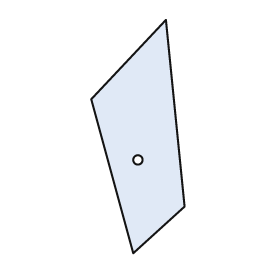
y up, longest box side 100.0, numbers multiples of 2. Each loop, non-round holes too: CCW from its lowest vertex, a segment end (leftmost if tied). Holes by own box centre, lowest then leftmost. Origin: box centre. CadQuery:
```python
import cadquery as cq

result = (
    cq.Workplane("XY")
    .moveTo(-2.0, -50.0)
    .lineTo(20.0, -30.0)
    .lineTo(12.0, 50.0)
    .lineTo(-20.0, 16.0)
    .close()
    .moveTo(0.0, -10.0)
    .circle(2.0)
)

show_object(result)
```